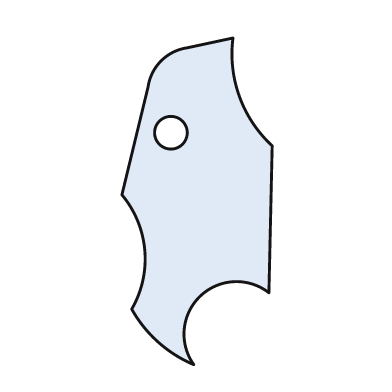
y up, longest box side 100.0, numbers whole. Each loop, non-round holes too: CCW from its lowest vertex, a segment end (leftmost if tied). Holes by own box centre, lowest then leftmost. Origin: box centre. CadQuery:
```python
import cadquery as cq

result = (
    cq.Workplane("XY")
    .moveTo(-1.0, -50.0)
    .threePointArc((1.0, -29.0), (22.0, -28.0))
    .lineTo(23.0, 17.0)
    .threePointArc((13.0, 32.0), (11.0, 50.0))
    .lineTo(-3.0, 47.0)
    .threePointArc((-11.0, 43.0), (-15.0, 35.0))
    .lineTo(-23.0, 2.0)
    .threePointArc((-16.0, -15.0), (-20.0, -33.0))
    .threePointArc((-12.0, -43.0), (-1.0, -50.0))
    .close()
    .moveTo(-8.0, 21.0)
    .circle(5.0)
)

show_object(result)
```